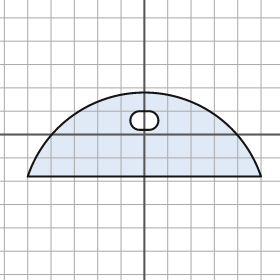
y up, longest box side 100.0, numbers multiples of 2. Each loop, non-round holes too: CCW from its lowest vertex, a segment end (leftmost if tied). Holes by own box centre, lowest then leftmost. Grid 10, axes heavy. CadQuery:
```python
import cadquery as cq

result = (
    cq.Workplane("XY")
    .moveTo(-50.0, -18.0)
    .lineTo(50.0, -18.0)
    .threePointArc((0.0, 18.0), (-50.0, -18.0))
    .close()
    .moveTo(-2.0, 2.0)
    .lineTo(2.0, 2.0)
    .threePointArc((6.0, 6.0), (2.0, 10.0))
    .lineTo(-2.0, 10.0)
    .threePointArc((-6.0, 6.0), (-2.0, 2.0))
    .close()
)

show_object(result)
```